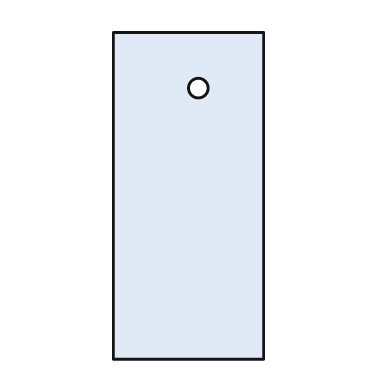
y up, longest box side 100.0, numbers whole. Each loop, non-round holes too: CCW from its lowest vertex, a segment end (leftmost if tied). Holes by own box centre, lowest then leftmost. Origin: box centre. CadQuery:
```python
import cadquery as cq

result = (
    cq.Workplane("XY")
    .moveTo(-23.0, -50.0)
    .lineTo(23.0, -50.0)
    .lineTo(23.0, 50.0)
    .lineTo(-23.0, 50.0)
    .close()
    .moveTo(3.0, 33.0)
    .circle(3.0)
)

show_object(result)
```